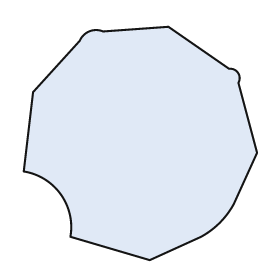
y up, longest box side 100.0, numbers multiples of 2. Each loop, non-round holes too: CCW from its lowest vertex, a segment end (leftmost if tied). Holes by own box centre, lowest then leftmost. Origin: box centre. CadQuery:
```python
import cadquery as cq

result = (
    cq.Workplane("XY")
    .moveTo(4.0, -50.0)
    .lineTo(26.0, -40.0)
    .threePointArc((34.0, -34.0), (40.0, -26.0))
    .lineTo(50.0, -4.0)
    .lineTo(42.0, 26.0)
    .threePointArc((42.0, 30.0), (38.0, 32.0))
    .lineTo(12.0, 50.0)
    .lineTo(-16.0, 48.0)
    .threePointArc((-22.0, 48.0), (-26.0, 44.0))
    .lineTo(-46.0, 22.0)
    .lineTo(-50.0, -12.0)
    .threePointArc((-34.0, -22.0), (-30.0, -40.0))
    .close()
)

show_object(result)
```